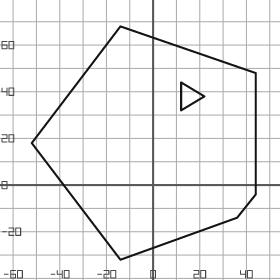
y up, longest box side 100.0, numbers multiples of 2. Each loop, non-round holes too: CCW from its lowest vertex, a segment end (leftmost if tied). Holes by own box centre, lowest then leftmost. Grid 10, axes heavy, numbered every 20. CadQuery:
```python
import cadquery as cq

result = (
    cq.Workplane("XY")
    .moveTo(-14.0, -32.0)
    .lineTo(36.0, -14.0)
    .lineTo(44.0, -4.0)
    .lineTo(44.0, 48.0)
    .lineTo(-14.0, 68.0)
    .lineTo(-52.0, 18.0)
    .close()
    .moveTo(12.0, 32.0)
    .lineTo(22.0, 38.0)
    .lineTo(12.0, 44.0)
    .close()
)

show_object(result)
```